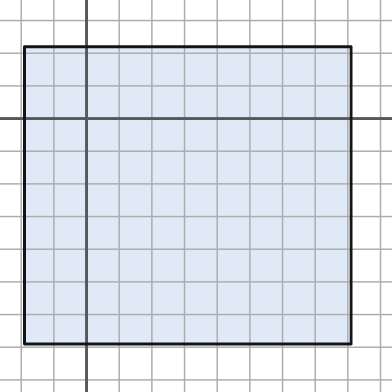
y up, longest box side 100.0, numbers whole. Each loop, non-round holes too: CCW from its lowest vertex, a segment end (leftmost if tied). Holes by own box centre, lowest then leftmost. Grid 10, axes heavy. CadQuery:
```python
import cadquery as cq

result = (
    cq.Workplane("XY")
    .moveTo(-19.0, -69.0)
    .lineTo(81.0, -69.0)
    .lineTo(81.0, 22.0)
    .lineTo(-19.0, 22.0)
    .close()
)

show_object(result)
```